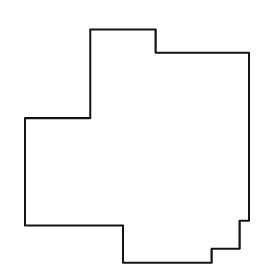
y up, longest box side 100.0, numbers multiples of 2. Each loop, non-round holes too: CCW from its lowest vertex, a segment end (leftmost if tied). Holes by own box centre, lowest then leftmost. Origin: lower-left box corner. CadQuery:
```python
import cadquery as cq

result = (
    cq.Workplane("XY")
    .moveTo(42.0, 0.0)
    .lineTo(80.0, 0.0)
    .lineTo(80.0, 6.0)
    .lineTo(92.0, 6.0)
    .lineTo(92.0, 18.0)
    .lineTo(96.0, 18.0)
    .lineTo(96.0, 90.0)
    .lineTo(56.0, 90.0)
    .lineTo(56.0, 100.0)
    .lineTo(28.0, 100.0)
    .lineTo(28.0, 62.0)
    .lineTo(0.0, 62.0)
    .lineTo(0.0, 16.0)
    .lineTo(42.0, 16.0)
    .close()
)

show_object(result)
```